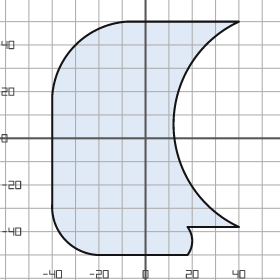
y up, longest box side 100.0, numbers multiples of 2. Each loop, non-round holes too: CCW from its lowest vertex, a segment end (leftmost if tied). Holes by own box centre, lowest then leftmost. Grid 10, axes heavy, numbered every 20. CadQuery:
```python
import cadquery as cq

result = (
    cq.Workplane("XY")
    .moveTo(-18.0, -50.0)
    .lineTo(18.0, -50.0)
    .threePointArc((20.0, -44.0), (18.0, -38.0))
    .lineTo(40.0, -38.0)
    .threePointArc((12.0, 6.0), (40.0, 50.0))
    .lineTo(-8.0, 50.0)
    .threePointArc((-30.0, 40.0), (-40.0, 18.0))
    .lineTo(-40.0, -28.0)
    .threePointArc((-34.0, -44.0), (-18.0, -50.0))
    .close()
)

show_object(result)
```